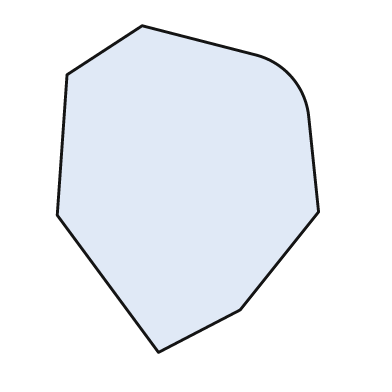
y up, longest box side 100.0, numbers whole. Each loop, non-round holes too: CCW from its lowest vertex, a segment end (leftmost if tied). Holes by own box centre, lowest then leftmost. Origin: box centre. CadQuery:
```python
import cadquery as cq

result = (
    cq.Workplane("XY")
    .moveTo(-9.0, -50.0)
    .lineTo(16.0, -37.0)
    .lineTo(40.0, -7.0)
    .lineTo(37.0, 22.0)
    .threePointArc((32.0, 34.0), (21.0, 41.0))
    .lineTo(-14.0, 50.0)
    .lineTo(-37.0, 35.0)
    .lineTo(-40.0, -8.0)
    .close()
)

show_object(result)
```